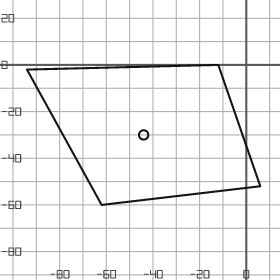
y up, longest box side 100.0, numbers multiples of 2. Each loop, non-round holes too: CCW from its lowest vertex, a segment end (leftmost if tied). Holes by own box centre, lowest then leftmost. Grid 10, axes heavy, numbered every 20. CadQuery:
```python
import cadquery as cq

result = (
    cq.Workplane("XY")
    .moveTo(-62.0, -60.0)
    .lineTo(6.0, -52.0)
    .lineTo(-12.0, 0.0)
    .lineTo(-94.0, -2.0)
    .close()
    .moveTo(-44.0, -30.0)
    .circle(2.0)
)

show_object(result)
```